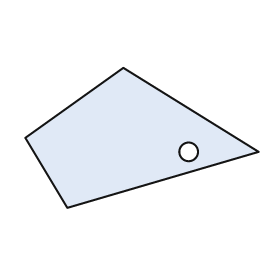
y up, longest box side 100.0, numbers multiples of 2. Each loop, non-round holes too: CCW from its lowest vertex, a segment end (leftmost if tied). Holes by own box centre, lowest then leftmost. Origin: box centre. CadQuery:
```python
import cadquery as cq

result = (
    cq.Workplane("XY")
    .moveTo(-32.0, -30.0)
    .lineTo(50.0, -6.0)
    .lineTo(-8.0, 30.0)
    .lineTo(-50.0, 0.0)
    .close()
    .moveTo(20.0, -6.0)
    .circle(4.0)
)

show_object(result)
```